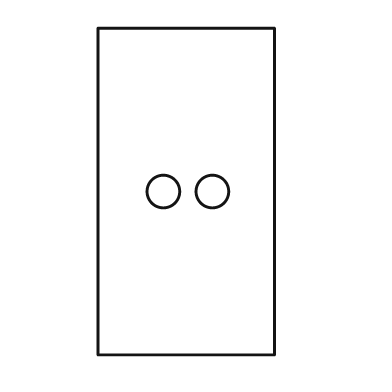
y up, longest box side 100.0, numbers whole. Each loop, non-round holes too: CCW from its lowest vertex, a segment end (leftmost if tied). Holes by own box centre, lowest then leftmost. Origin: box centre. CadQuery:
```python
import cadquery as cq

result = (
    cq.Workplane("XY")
    .moveTo(-27.0, -50.0)
    .lineTo(27.0, -50.0)
    .lineTo(27.0, 50.0)
    .lineTo(-27.0, 50.0)
    .close()
    .moveTo(-7.0, 0.0)
    .circle(5.0)
    .moveTo(8.0, 0.0)
    .circle(5.0)
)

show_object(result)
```